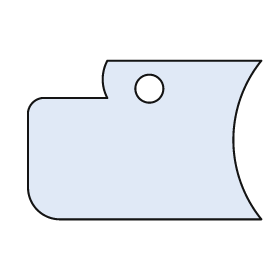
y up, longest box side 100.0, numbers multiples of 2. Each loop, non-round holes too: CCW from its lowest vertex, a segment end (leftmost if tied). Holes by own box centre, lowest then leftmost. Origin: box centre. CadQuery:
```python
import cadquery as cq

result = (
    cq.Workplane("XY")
    .moveTo(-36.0, -34.0)
    .lineTo(50.0, -34.0)
    .threePointArc((38.0, 0.0), (50.0, 34.0))
    .lineTo(-16.0, 34.0)
    .threePointArc((-18.0, 26.0), (-16.0, 18.0))
    .lineTo(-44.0, 18.0)
    .threePointArc((-48.0, 16.0), (-50.0, 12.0))
    .lineTo(-50.0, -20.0)
    .threePointArc((-46.0, -30.0), (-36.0, -34.0))
    .close()
    .moveTo(2.0, 22.0)
    .circle(6.0)
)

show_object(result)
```